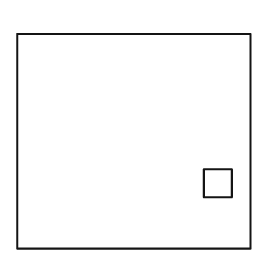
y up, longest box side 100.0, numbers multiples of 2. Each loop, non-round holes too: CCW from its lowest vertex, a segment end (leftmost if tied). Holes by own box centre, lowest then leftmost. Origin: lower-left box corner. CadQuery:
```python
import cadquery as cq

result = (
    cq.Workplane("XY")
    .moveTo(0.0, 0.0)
    .lineTo(100.0, 0.0)
    .lineTo(100.0, 92.0)
    .lineTo(0.0, 92.0)
    .close()
    .moveTo(80.0, 22.0)
    .lineTo(92.0, 22.0)
    .lineTo(92.0, 34.0)
    .lineTo(80.0, 34.0)
    .close()
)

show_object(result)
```